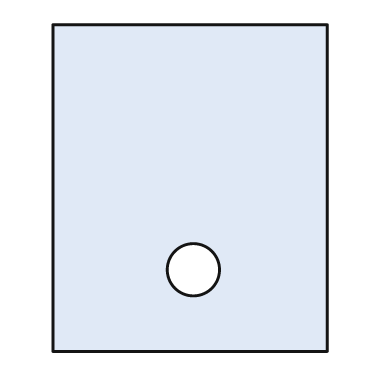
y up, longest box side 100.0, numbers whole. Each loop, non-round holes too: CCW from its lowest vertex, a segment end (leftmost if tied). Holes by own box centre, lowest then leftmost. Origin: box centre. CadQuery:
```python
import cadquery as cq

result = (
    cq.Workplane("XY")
    .moveTo(-42.0, -50.0)
    .lineTo(42.0, -50.0)
    .lineTo(42.0, 50.0)
    .lineTo(-42.0, 50.0)
    .close()
    .moveTo(1.0, -25.0)
    .circle(8.0)
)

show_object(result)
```